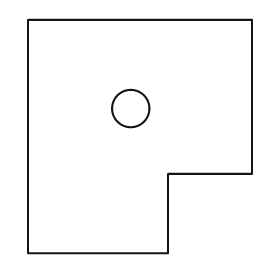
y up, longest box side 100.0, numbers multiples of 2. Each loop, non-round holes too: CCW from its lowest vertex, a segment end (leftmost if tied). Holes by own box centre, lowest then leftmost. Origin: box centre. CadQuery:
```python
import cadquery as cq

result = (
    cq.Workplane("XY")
    .moveTo(-48.0, -50.0)
    .lineTo(12.0, -50.0)
    .lineTo(12.0, -16.0)
    .lineTo(48.0, -16.0)
    .lineTo(48.0, 50.0)
    .lineTo(-48.0, 50.0)
    .close()
    .moveTo(-4.0, 12.0)
    .circle(8.0)
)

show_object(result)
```